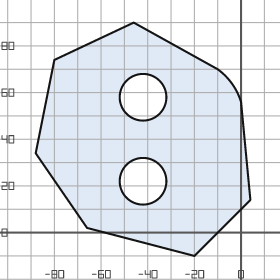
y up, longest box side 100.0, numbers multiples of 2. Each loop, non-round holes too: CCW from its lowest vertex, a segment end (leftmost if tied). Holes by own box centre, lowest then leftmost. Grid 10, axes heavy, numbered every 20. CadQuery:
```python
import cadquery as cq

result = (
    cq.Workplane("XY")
    .moveTo(-20.0, -10.0)
    .lineTo(4.0, 14.0)
    .lineTo(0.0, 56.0)
    .threePointArc((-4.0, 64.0), (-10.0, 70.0))
    .lineTo(-46.0, 90.0)
    .lineTo(-80.0, 74.0)
    .lineTo(-88.0, 34.0)
    .lineTo(-66.0, 2.0)
    .close()
    .moveTo(-42.0, 22.0)
    .circle(10.0)
    .moveTo(-42.0, 58.0)
    .circle(10.0)
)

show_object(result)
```